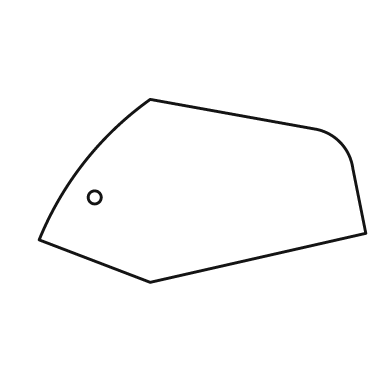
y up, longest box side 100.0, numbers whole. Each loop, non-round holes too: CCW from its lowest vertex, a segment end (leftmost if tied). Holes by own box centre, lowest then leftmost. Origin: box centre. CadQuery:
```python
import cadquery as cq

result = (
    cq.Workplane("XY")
    .moveTo(-16.0, -28.0)
    .lineTo(50.0, -13.0)
    .lineTo(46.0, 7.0)
    .threePointArc((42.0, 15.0), (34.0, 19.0))
    .lineTo(-16.0, 28.0)
    .threePointArc((-36.0, 9.0), (-50.0, -15.0))
    .close()
    .moveTo(-33.0, -2.0)
    .circle(2.0)
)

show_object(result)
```